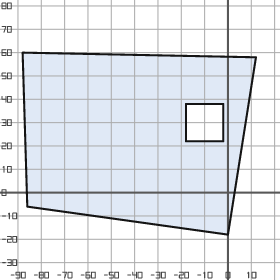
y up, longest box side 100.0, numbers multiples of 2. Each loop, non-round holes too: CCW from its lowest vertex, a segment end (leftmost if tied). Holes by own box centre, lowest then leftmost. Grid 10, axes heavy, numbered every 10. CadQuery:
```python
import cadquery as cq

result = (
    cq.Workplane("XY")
    .moveTo(0.0, -18.0)
    .lineTo(12.0, 58.0)
    .lineTo(-88.0, 60.0)
    .lineTo(-86.0, -6.0)
    .close()
    .moveTo(-18.0, 22.0)
    .lineTo(-2.0, 22.0)
    .lineTo(-2.0, 38.0)
    .lineTo(-18.0, 38.0)
    .close()
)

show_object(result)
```